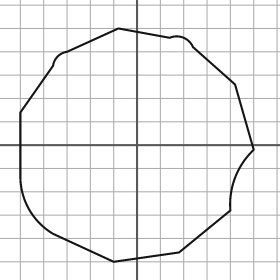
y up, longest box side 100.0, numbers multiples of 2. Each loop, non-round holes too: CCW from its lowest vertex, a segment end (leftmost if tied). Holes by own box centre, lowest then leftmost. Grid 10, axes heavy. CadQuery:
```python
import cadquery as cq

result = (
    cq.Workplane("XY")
    .moveTo(-10.0, -50.0)
    .lineTo(18.0, -46.0)
    .lineTo(40.0, -28.0)
    .threePointArc((42.0, -14.0), (50.0, -2.0))
    .lineTo(42.0, 26.0)
    .lineTo(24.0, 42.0)
    .threePointArc((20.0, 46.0), (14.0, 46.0))
    .lineTo(-8.0, 50.0)
    .lineTo(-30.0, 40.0)
    .threePointArc((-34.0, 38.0), (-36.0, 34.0))
    .lineTo(-50.0, 14.0)
    .lineTo(-50.0, -14.0)
    .threePointArc((-46.0, -28.0), (-36.0, -38.0))
    .close()
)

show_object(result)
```